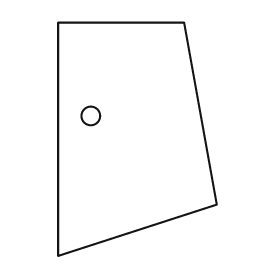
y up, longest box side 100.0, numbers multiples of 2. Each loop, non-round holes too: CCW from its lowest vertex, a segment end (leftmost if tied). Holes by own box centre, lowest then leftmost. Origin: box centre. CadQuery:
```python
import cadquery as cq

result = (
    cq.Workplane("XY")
    .moveTo(-34.0, -50.0)
    .lineTo(34.0, -28.0)
    .lineTo(20.0, 50.0)
    .lineTo(-34.0, 50.0)
    .close()
    .moveTo(-20.0, 10.0)
    .circle(4.0)
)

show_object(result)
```